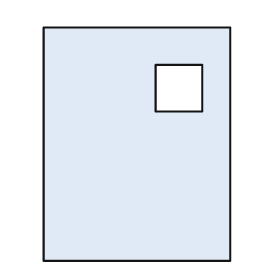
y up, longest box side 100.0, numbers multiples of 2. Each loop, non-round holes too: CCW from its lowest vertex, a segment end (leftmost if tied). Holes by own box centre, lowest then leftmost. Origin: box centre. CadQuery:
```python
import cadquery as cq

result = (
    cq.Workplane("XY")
    .moveTo(-40.0, -50.0)
    .lineTo(40.0, -50.0)
    .lineTo(40.0, 50.0)
    .lineTo(-40.0, 50.0)
    .close()
    .moveTo(8.0, 14.0)
    .lineTo(28.0, 14.0)
    .lineTo(28.0, 34.0)
    .lineTo(8.0, 34.0)
    .close()
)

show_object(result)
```